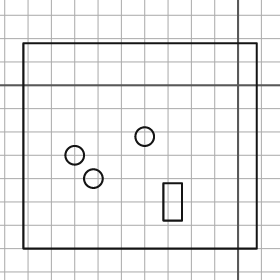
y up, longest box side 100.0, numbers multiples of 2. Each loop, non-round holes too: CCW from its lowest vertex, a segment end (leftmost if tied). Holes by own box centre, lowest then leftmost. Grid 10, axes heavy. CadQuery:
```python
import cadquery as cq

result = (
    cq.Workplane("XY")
    .moveTo(-92.0, -70.0)
    .lineTo(8.0, -70.0)
    .lineTo(8.0, 18.0)
    .lineTo(-92.0, 18.0)
    .close()
    .moveTo(-32.0, -58.0)
    .lineTo(-24.0, -58.0)
    .lineTo(-24.0, -42.0)
    .lineTo(-32.0, -42.0)
    .close()
    .moveTo(-62.0, -40.0)
    .circle(4.0)
    .moveTo(-70.0, -30.0)
    .circle(4.0)
    .moveTo(-40.0, -22.0)
    .circle(4.0)
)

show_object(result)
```